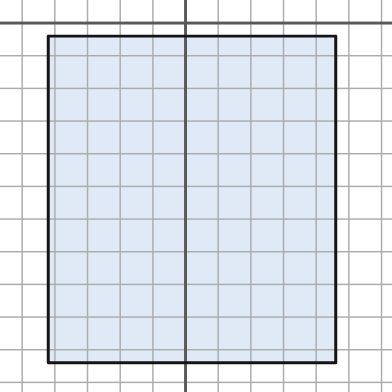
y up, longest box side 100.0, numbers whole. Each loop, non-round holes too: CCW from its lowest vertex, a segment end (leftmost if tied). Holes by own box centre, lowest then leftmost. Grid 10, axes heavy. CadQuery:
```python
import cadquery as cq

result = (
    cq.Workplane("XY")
    .moveTo(-42.0, -104.0)
    .lineTo(46.0, -104.0)
    .lineTo(46.0, -4.0)
    .lineTo(-42.0, -4.0)
    .close()
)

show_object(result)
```